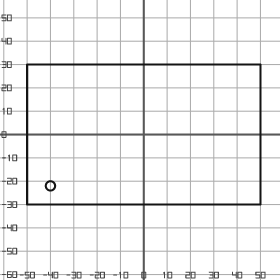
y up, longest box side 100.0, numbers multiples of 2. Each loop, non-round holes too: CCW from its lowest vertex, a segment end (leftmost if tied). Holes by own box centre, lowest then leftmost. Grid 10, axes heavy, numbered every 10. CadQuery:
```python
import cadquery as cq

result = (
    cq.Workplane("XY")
    .moveTo(-50.0, -30.0)
    .lineTo(50.0, -30.0)
    .lineTo(50.0, 30.0)
    .lineTo(-50.0, 30.0)
    .close()
    .moveTo(-40.0, -22.0)
    .circle(2.0)
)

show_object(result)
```